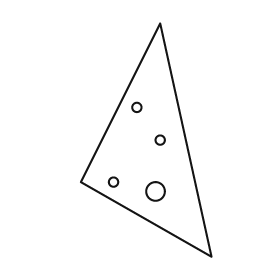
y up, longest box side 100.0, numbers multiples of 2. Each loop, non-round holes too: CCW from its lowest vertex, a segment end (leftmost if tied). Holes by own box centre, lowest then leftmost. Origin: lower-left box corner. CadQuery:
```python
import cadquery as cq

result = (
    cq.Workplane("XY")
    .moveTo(56.0, 0.0)
    .lineTo(34.0, 100.0)
    .lineTo(0.0, 32.0)
    .close()
    .moveTo(32.0, 28.0)
    .circle(4.0)
    .moveTo(14.0, 32.0)
    .circle(2.0)
    .moveTo(34.0, 50.0)
    .circle(2.0)
    .moveTo(24.0, 64.0)
    .circle(2.0)
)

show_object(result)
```